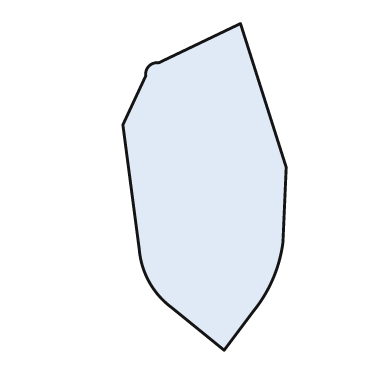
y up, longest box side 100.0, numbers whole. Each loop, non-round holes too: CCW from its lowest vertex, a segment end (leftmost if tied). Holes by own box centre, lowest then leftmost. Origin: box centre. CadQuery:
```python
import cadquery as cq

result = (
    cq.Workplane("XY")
    .moveTo(6.0, -50.0)
    .lineTo(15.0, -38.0)
    .threePointArc((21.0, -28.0), (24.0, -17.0))
    .lineTo(25.0, 6.0)
    .lineTo(11.0, 50.0)
    .lineTo(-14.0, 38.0)
    .threePointArc((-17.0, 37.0), (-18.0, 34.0))
    .lineTo(-25.0, 19.0)
    .lineTo(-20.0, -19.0)
    .threePointArc((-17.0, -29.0), (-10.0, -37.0))
    .close()
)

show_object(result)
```